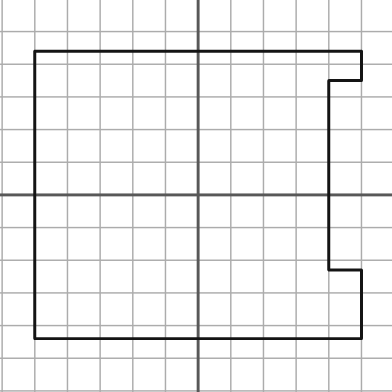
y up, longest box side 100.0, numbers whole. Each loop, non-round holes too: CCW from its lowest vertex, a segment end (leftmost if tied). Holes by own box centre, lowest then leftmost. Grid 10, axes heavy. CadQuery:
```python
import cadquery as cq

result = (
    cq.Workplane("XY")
    .moveTo(-50.0, -44.0)
    .lineTo(50.0, -44.0)
    .lineTo(50.0, -23.0)
    .lineTo(40.0, -23.0)
    .lineTo(40.0, 35.0)
    .lineTo(50.0, 35.0)
    .lineTo(50.0, 44.0)
    .lineTo(-50.0, 44.0)
    .close()
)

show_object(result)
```